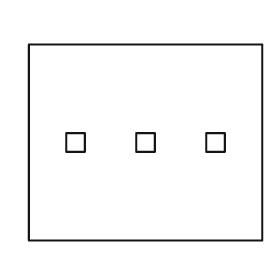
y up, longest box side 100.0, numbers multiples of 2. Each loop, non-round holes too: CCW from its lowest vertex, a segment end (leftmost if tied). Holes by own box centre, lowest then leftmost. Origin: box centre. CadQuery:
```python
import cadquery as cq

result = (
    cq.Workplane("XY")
    .moveTo(-50.0, -42.0)
    .lineTo(50.0, -42.0)
    .lineTo(50.0, 42.0)
    .lineTo(-50.0, 42.0)
    .close()
    .moveTo(-34.0, -4.0)
    .lineTo(-26.0, -4.0)
    .lineTo(-26.0, 4.0)
    .lineTo(-34.0, 4.0)
    .close()
    .moveTo(-4.0, -4.0)
    .lineTo(4.0, -4.0)
    .lineTo(4.0, 4.0)
    .lineTo(-4.0, 4.0)
    .close()
    .moveTo(26.0, -4.0)
    .lineTo(34.0, -4.0)
    .lineTo(34.0, 4.0)
    .lineTo(26.0, 4.0)
    .close()
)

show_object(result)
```